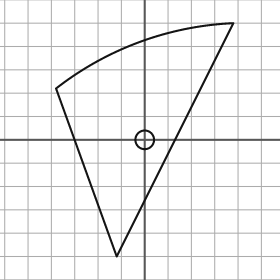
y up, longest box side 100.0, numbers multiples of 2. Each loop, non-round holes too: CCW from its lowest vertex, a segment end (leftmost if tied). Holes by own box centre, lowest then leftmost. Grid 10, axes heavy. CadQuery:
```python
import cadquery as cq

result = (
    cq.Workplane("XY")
    .moveTo(-12.0, -50.0)
    .lineTo(38.0, 50.0)
    .threePointArc((-2.0, 42.0), (-38.0, 22.0))
    .close()
    .moveTo(0.0, 0.0)
    .circle(4.0)
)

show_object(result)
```